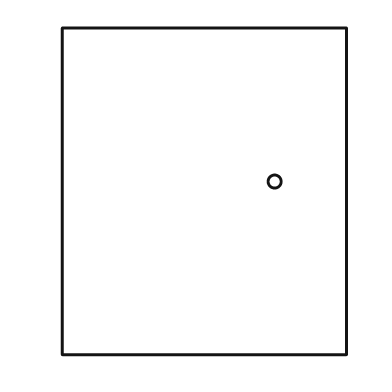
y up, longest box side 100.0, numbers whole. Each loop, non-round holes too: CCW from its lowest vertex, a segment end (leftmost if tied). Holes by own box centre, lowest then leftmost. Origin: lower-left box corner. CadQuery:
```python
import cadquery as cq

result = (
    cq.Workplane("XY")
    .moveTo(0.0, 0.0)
    .lineTo(87.0, 0.0)
    .lineTo(87.0, 100.0)
    .lineTo(0.0, 100.0)
    .close()
    .moveTo(65.0, 53.0)
    .circle(2.0)
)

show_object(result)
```